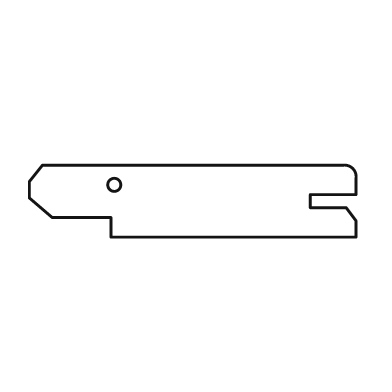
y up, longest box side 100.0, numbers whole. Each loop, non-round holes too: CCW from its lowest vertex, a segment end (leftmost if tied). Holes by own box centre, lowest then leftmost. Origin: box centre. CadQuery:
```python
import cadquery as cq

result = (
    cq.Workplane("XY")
    .moveTo(-25.0, -11.0)
    .lineTo(50.0, -11.0)
    .lineTo(50.0, -6.0)
    .lineTo(47.0, -2.0)
    .lineTo(36.0, -2.0)
    .lineTo(36.0, 2.0)
    .lineTo(50.0, 2.0)
    .lineTo(50.0, 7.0)
    .threePointArc((49.0, 10.0), (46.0, 11.0))
    .lineTo(-46.0, 11.0)
    .lineTo(-50.0, 6.0)
    .lineTo(-50.0, 1.0)
    .lineTo(-43.0, -5.0)
    .lineTo(-25.0, -5.0)
    .close()
    .moveTo(-24.0, 5.0)
    .circle(2.0)
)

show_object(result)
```